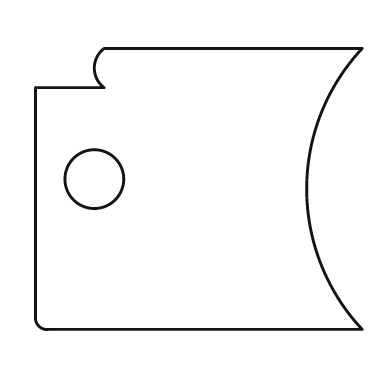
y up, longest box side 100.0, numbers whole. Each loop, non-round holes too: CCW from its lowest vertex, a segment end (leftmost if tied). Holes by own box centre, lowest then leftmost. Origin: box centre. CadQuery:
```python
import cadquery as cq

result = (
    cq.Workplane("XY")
    .moveTo(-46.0, -43.0)
    .lineTo(50.0, -43.0)
    .threePointArc((33.0, 0.0), (50.0, 43.0))
    .lineTo(-29.0, 43.0)
    .threePointArc((-32.0, 37.0), (-29.0, 31.0))
    .lineTo(-50.0, 31.0)
    .lineTo(-50.0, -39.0)
    .threePointArc((-49.0, -42.0), (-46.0, -43.0))
    .close()
    .moveTo(-32.0, 3.0)
    .circle(9.0)
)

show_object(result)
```